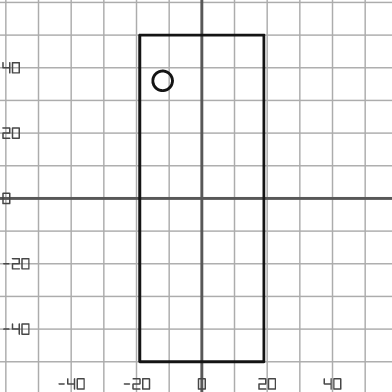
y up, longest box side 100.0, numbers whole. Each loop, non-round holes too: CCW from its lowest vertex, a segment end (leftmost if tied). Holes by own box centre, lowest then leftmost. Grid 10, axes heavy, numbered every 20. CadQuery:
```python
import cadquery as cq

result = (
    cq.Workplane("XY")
    .moveTo(-19.0, -50.0)
    .lineTo(19.0, -50.0)
    .lineTo(19.0, 50.0)
    .lineTo(-19.0, 50.0)
    .close()
    .moveTo(-12.0, 36.0)
    .circle(3.0)
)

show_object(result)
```